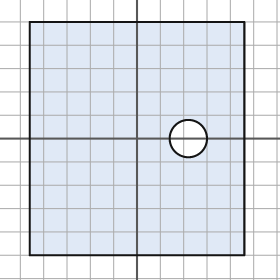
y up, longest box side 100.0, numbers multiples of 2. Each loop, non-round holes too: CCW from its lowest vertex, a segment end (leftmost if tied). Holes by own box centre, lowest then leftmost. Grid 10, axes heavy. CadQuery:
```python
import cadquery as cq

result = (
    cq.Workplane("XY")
    .moveTo(-46.0, -50.0)
    .lineTo(46.0, -50.0)
    .lineTo(46.0, 50.0)
    .lineTo(-46.0, 50.0)
    .close()
    .moveTo(22.0, 0.0)
    .circle(8.0)
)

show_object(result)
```